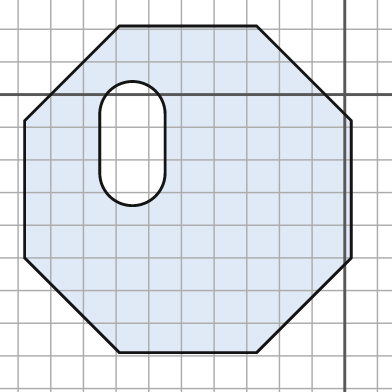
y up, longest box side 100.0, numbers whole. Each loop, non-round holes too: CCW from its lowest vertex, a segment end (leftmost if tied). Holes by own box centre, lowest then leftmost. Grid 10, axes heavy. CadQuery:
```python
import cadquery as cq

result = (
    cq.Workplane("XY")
    .moveTo(-69.0, -79.0)
    .lineTo(-27.0, -79.0)
    .lineTo(2.0, -50.0)
    .lineTo(2.0, -8.0)
    .lineTo(-27.0, 21.0)
    .lineTo(-69.0, 21.0)
    .lineTo(-98.0, -8.0)
    .lineTo(-98.0, -50.0)
    .close()
    .moveTo(-75.0, -24.0)
    .threePointArc((-65.0, -34.0), (-55.0, -24.0))
    .lineTo(-55.0, -6.0)
    .threePointArc((-65.0, 4.0), (-75.0, -6.0))
    .close()
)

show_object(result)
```